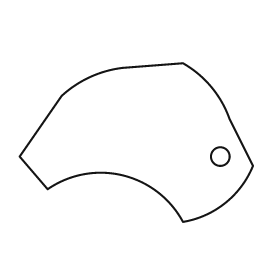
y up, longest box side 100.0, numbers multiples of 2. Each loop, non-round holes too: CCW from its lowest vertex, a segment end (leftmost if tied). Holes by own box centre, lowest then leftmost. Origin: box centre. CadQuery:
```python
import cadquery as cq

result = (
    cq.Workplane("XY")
    .moveTo(20.0, -34.0)
    .threePointArc((38.0, -26.0), (50.0, -10.0))
    .lineTo(40.0, 10.0)
    .threePointArc((32.0, 24.0), (20.0, 34.0))
    .lineTo(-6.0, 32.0)
    .threePointArc((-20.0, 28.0), (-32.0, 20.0))
    .lineTo(-50.0, -6.0)
    .lineTo(-38.0, -20.0)
    .threePointArc((-6.0, -14.0), (20.0, -34.0))
    .close()
    .moveTo(36.0, -6.0)
    .circle(4.0)
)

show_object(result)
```